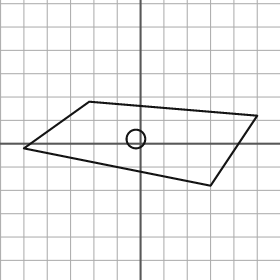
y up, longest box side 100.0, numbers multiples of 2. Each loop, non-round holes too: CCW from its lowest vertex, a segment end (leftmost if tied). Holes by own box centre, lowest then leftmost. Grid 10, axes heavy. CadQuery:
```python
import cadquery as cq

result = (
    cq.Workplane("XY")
    .moveTo(30.0, -18.0)
    .lineTo(50.0, 12.0)
    .lineTo(-22.0, 18.0)
    .lineTo(-50.0, -2.0)
    .close()
    .moveTo(-2.0, 2.0)
    .circle(4.0)
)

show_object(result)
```